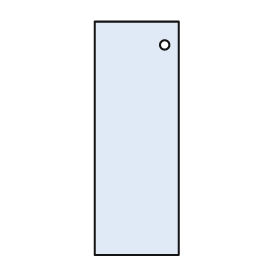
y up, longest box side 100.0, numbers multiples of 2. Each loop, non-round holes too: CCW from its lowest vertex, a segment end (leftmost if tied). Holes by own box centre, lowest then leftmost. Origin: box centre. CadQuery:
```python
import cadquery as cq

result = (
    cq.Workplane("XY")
    .moveTo(-18.0, -50.0)
    .lineTo(18.0, -50.0)
    .lineTo(18.0, 50.0)
    .lineTo(-18.0, 50.0)
    .close()
    .moveTo(12.0, 40.0)
    .circle(2.0)
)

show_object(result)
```